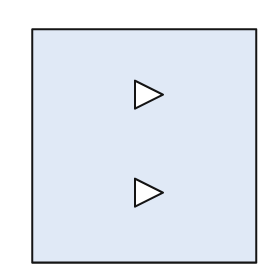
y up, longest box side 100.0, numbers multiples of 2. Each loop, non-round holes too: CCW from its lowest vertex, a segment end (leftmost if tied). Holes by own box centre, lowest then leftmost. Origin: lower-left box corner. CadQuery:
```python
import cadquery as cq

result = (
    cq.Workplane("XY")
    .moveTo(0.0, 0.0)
    .lineTo(96.0, 0.0)
    .lineTo(96.0, 100.0)
    .lineTo(0.0, 100.0)
    .close()
    .moveTo(44.0, 24.0)
    .lineTo(56.0, 30.0)
    .lineTo(44.0, 36.0)
    .close()
    .moveTo(44.0, 66.0)
    .lineTo(56.0, 72.0)
    .lineTo(44.0, 78.0)
    .close()
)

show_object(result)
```